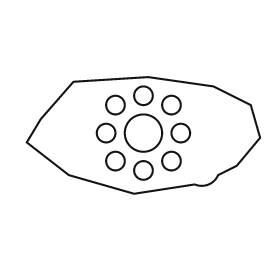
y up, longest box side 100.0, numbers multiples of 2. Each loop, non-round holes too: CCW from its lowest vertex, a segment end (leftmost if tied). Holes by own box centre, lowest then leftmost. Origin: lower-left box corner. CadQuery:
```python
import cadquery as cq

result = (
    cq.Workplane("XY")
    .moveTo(46.0, 0.0)
    .lineTo(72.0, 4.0)
    .threePointArc((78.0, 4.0), (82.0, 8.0))
    .lineTo(90.0, 12.0)
    .lineTo(100.0, 24.0)
    .lineTo(96.0, 38.0)
    .lineTo(80.0, 46.0)
    .lineTo(52.0, 50.0)
    .lineTo(20.0, 48.0)
    .lineTo(6.0, 32.0)
    .lineTo(0.0, 22.0)
    .lineTo(18.0, 8.0)
    .close()
    .moveTo(50.0, 10.0)
    .circle(4.0)
    .moveTo(38.0, 14.0)
    .circle(4.0)
    .moveTo(62.0, 14.0)
    .circle(4.0)
    .moveTo(34.0, 26.0)
    .circle(4.0)
    .moveTo(50.0, 26.0)
    .circle(8.0)
    .moveTo(66.0, 26.0)
    .circle(4.0)
    .moveTo(38.0, 38.0)
    .circle(4.0)
    .moveTo(62.0, 38.0)
    .circle(4.0)
    .moveTo(50.0, 42.0)
    .circle(4.0)
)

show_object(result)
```